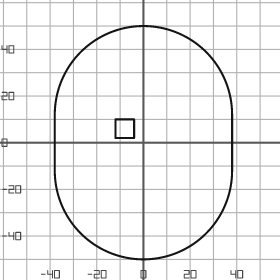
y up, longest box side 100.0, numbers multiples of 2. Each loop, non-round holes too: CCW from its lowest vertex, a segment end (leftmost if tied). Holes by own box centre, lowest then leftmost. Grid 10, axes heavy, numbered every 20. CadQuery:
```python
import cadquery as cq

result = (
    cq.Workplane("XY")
    .moveTo(-38.0, -12.0)
    .threePointArc((0.0, -50.0), (38.0, -12.0))
    .lineTo(38.0, 12.0)
    .threePointArc((0.0, 50.0), (-38.0, 12.0))
    .close()
    .moveTo(-12.0, 2.0)
    .lineTo(-4.0, 2.0)
    .lineTo(-4.0, 10.0)
    .lineTo(-12.0, 10.0)
    .close()
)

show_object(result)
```